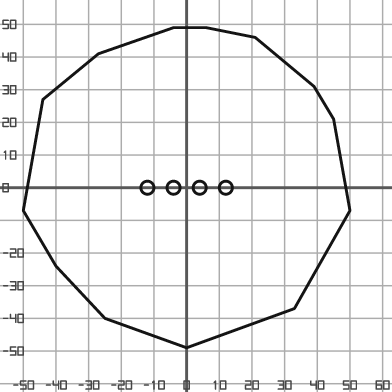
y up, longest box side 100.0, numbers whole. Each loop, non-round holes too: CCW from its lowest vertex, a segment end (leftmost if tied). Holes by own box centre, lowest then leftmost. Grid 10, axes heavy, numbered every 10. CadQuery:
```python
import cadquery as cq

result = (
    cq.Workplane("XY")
    .moveTo(0.0, -49.0)
    .lineTo(33.0, -37.0)
    .lineTo(50.0, -7.0)
    .lineTo(45.0, 21.0)
    .lineTo(39.0, 31.0)
    .lineTo(21.0, 46.0)
    .lineTo(6.0, 49.0)
    .lineTo(-4.0, 49.0)
    .lineTo(-27.0, 41.0)
    .lineTo(-44.0, 27.0)
    .lineTo(-50.0, -7.0)
    .lineTo(-40.0, -24.0)
    .lineTo(-25.0, -40.0)
    .close()
    .moveTo(-12.0, 0.0)
    .circle(2.0)
    .moveTo(-4.0, 0.0)
    .circle(2.0)
    .moveTo(4.0, 0.0)
    .circle(2.0)
    .moveTo(12.0, 0.0)
    .circle(2.0)
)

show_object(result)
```